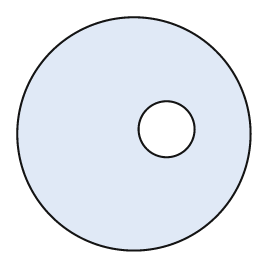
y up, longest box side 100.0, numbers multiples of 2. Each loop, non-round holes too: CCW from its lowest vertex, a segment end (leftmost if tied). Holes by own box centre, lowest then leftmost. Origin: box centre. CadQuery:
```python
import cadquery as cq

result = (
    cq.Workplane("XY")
    .moveTo(0.0, 0.0)
    .circle(50.0)
    .moveTo(14.0, 2.0)
    .circle(12.0)
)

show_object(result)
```